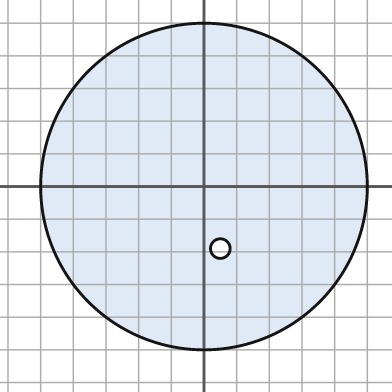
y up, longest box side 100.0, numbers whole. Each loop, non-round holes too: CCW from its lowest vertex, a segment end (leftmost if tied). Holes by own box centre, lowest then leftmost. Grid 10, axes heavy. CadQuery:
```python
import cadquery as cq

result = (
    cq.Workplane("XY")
    .moveTo(0.0, 0.0)
    .circle(50.0)
    .moveTo(5.0, -19.0)
    .circle(3.0)
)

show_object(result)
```